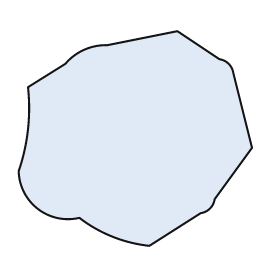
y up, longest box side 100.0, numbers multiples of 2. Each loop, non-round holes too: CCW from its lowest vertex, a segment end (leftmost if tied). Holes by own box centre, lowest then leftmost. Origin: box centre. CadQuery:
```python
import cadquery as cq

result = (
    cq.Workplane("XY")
    .moveTo(6.0, -46.0)
    .lineTo(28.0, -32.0)
    .threePointArc((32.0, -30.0), (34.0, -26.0))
    .lineTo(50.0, -4.0)
    .lineTo(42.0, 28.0)
    .threePointArc((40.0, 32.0), (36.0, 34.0))
    .lineTo(18.0, 46.0)
    .lineTo(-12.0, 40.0)
    .threePointArc((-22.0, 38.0), (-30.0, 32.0))
    .lineTo(-46.0, 22.0)
    .threePointArc((-46.0, 4.0), (-50.0, -14.0))
    .threePointArc((-42.0, -30.0), (-24.0, -34.0))
    .threePointArc((-10.0, -42.0), (6.0, -46.0))
    .close()
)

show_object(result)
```